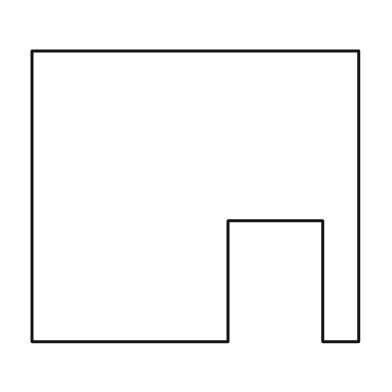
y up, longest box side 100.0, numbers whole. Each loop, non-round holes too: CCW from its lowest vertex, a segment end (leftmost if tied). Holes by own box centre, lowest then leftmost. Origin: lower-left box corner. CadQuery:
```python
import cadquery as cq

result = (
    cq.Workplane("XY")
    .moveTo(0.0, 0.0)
    .lineTo(60.0, 0.0)
    .lineTo(60.0, 37.0)
    .lineTo(89.0, 37.0)
    .lineTo(89.0, 0.0)
    .lineTo(100.0, 0.0)
    .lineTo(100.0, 89.0)
    .lineTo(0.0, 89.0)
    .close()
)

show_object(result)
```